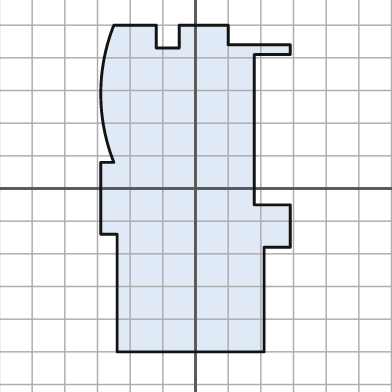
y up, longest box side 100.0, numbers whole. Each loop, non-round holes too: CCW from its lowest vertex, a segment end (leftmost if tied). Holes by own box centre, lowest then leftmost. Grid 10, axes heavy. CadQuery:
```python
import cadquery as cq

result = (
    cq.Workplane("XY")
    .moveTo(-24.0, -50.0)
    .lineTo(21.0, -50.0)
    .lineTo(21.0, -18.0)
    .lineTo(29.0, -18.0)
    .lineTo(29.0, -5.0)
    .lineTo(18.0, -5.0)
    .lineTo(18.0, 41.0)
    .lineTo(29.0, 41.0)
    .lineTo(29.0, 44.0)
    .lineTo(10.0, 44.0)
    .lineTo(10.0, 50.0)
    .lineTo(-5.0, 50.0)
    .lineTo(-5.0, 43.0)
    .lineTo(-12.0, 43.0)
    .lineTo(-12.0, 50.0)
    .lineTo(-25.0, 50.0)
    .threePointArc((-29.0, 29.0), (-25.0, 8.0))
    .lineTo(-29.0, 8.0)
    .lineTo(-29.0, -14.0)
    .lineTo(-24.0, -14.0)
    .close()
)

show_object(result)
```